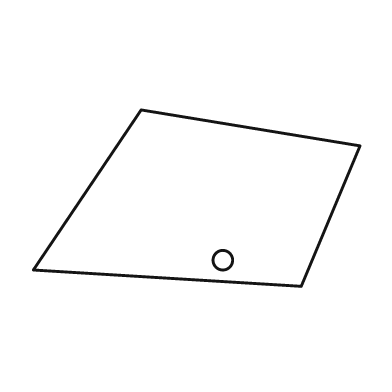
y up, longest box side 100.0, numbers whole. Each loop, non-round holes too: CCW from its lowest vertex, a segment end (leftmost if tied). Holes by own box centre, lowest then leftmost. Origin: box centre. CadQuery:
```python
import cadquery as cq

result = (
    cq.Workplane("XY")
    .moveTo(32.0, -27.0)
    .lineTo(50.0, 16.0)
    .lineTo(-17.0, 27.0)
    .lineTo(-50.0, -22.0)
    .close()
    .moveTo(8.0, -19.0)
    .circle(3.0)
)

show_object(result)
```